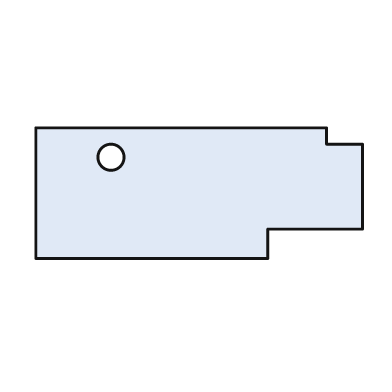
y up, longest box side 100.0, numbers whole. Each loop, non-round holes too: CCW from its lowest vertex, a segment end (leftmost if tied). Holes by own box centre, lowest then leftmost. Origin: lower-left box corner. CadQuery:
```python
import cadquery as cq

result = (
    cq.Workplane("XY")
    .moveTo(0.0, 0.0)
    .lineTo(71.0, 0.0)
    .lineTo(71.0, 9.0)
    .lineTo(100.0, 9.0)
    .lineTo(100.0, 35.0)
    .lineTo(89.0, 35.0)
    .lineTo(89.0, 40.0)
    .lineTo(0.0, 40.0)
    .close()
    .moveTo(23.0, 31.0)
    .circle(4.0)
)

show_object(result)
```